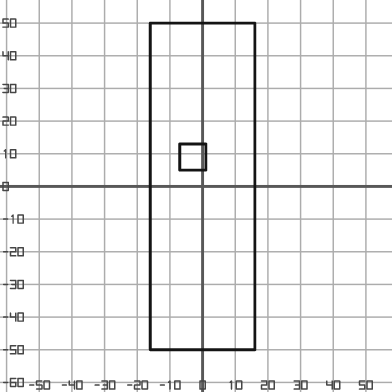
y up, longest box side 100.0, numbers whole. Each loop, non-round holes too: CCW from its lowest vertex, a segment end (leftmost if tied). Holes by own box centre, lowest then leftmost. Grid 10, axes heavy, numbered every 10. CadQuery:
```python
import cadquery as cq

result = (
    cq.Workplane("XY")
    .moveTo(-16.0, -50.0)
    .lineTo(16.0, -50.0)
    .lineTo(16.0, 50.0)
    .lineTo(-16.0, 50.0)
    .close()
    .moveTo(-7.0, 5.0)
    .lineTo(1.0, 5.0)
    .lineTo(1.0, 13.0)
    .lineTo(-7.0, 13.0)
    .close()
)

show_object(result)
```